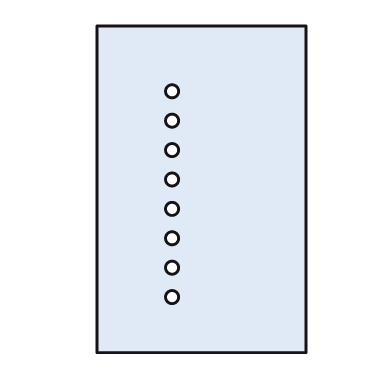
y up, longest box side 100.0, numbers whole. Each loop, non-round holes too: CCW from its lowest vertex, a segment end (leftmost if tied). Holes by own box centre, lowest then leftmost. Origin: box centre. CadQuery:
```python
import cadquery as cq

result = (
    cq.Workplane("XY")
    .moveTo(-32.0, -50.0)
    .lineTo(32.0, -50.0)
    .lineTo(32.0, 50.0)
    .lineTo(-32.0, 50.0)
    .close()
    .moveTo(-9.0, -33.0)
    .circle(2.0)
    .moveTo(-9.0, -24.0)
    .circle(2.0)
    .moveTo(-9.0, -15.0)
    .circle(2.0)
    .moveTo(-9.0, -6.0)
    .circle(2.0)
    .moveTo(-9.0, 3.0)
    .circle(2.0)
    .moveTo(-9.0, 12.0)
    .circle(2.0)
    .moveTo(-9.0, 21.0)
    .circle(2.0)
    .moveTo(-9.0, 30.0)
    .circle(2.0)
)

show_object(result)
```